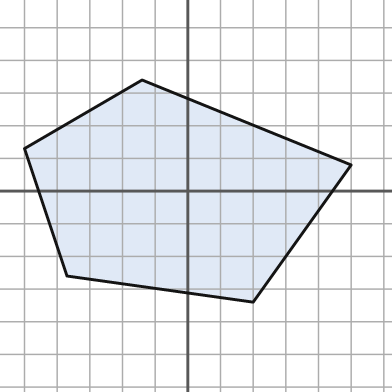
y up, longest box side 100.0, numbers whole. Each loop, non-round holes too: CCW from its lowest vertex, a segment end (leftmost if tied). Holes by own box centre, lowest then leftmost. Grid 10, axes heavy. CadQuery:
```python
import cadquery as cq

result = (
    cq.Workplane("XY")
    .moveTo(20.0, -34.0)
    .lineTo(50.0, 8.0)
    .lineTo(-14.0, 34.0)
    .lineTo(-50.0, 13.0)
    .lineTo(-37.0, -26.0)
    .close()
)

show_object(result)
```